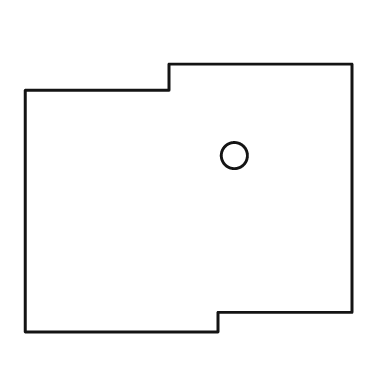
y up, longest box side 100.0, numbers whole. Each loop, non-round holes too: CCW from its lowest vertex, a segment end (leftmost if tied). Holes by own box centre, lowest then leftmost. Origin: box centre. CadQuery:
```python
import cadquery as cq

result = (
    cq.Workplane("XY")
    .moveTo(-50.0, -41.0)
    .lineTo(9.0, -41.0)
    .lineTo(9.0, -35.0)
    .lineTo(50.0, -35.0)
    .lineTo(50.0, 41.0)
    .lineTo(-6.0, 41.0)
    .lineTo(-6.0, 33.0)
    .lineTo(-50.0, 33.0)
    .close()
    .moveTo(14.0, 13.0)
    .circle(4.0)
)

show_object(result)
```